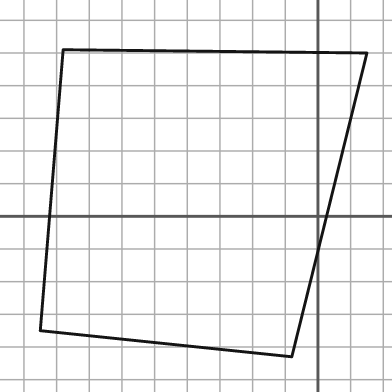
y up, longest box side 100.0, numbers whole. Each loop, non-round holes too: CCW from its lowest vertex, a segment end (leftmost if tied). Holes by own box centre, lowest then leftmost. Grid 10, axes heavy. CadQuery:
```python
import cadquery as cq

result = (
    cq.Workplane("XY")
    .moveTo(-8.0, -43.0)
    .lineTo(15.0, 50.0)
    .lineTo(-78.0, 51.0)
    .lineTo(-85.0, -35.0)
    .close()
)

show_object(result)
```